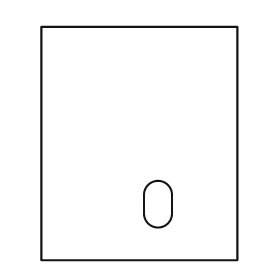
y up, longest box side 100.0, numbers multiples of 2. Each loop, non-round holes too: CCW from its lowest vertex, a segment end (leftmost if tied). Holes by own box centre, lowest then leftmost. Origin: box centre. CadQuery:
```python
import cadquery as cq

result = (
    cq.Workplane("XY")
    .moveTo(-42.0, -50.0)
    .lineTo(42.0, -50.0)
    .lineTo(42.0, 50.0)
    .lineTo(-42.0, 50.0)
    .close()
    .moveTo(2.0, -30.0)
    .threePointArc((8.0, -36.0), (14.0, -30.0))
    .lineTo(14.0, -22.0)
    .threePointArc((8.0, -16.0), (2.0, -22.0))
    .close()
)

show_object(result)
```